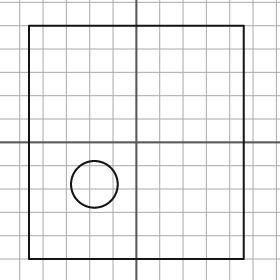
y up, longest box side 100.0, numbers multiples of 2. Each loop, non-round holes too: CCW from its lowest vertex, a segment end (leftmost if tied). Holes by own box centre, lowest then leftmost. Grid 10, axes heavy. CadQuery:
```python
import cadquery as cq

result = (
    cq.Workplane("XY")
    .moveTo(-46.0, -50.0)
    .lineTo(46.0, -50.0)
    .lineTo(46.0, 50.0)
    .lineTo(-46.0, 50.0)
    .close()
    .moveTo(-18.0, -18.0)
    .circle(10.0)
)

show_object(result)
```